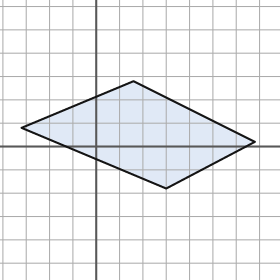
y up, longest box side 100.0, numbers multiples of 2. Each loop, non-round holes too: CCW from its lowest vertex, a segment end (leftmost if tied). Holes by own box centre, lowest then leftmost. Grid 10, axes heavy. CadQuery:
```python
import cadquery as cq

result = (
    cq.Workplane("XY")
    .moveTo(30.0, -18.0)
    .lineTo(68.0, 2.0)
    .lineTo(16.0, 28.0)
    .lineTo(-32.0, 8.0)
    .close()
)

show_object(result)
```